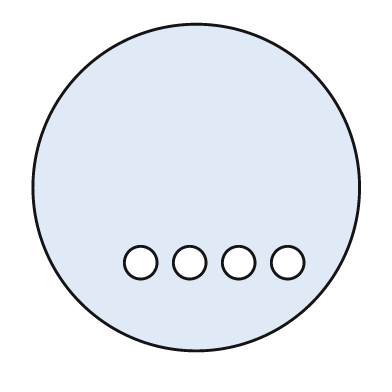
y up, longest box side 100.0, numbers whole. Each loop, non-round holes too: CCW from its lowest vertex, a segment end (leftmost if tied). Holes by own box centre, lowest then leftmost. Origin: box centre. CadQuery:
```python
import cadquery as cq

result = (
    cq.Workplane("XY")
    .moveTo(0.0, 0.0)
    .circle(50.0)
    .moveTo(-17.0, -23.0)
    .circle(5.0)
    .moveTo(-2.0, -23.0)
    .circle(5.0)
    .moveTo(13.0, -23.0)
    .circle(5.0)
    .moveTo(28.0, -23.0)
    .circle(5.0)
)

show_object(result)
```